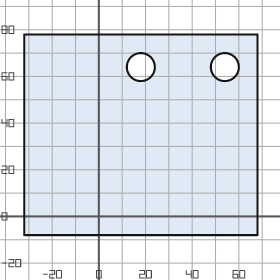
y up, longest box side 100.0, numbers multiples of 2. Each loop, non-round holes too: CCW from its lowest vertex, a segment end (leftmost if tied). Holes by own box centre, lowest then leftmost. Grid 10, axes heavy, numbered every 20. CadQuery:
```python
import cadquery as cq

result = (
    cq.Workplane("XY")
    .moveTo(-32.0, -8.0)
    .lineTo(68.0, -8.0)
    .lineTo(68.0, 78.0)
    .lineTo(-32.0, 78.0)
    .close()
    .moveTo(18.0, 64.0)
    .circle(6.0)
    .moveTo(54.0, 64.0)
    .circle(6.0)
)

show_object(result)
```